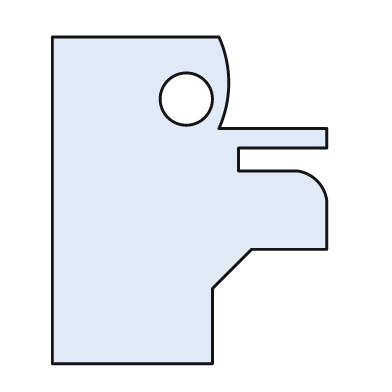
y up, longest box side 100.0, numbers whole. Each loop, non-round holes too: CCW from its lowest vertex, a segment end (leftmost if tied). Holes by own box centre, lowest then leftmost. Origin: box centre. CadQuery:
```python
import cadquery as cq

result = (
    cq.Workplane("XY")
    .moveTo(-42.0, -50.0)
    .lineTo(7.0, -50.0)
    .lineTo(7.0, -27.0)
    .lineTo(19.0, -15.0)
    .lineTo(42.0, -15.0)
    .lineTo(42.0, 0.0)
    .threePointArc((39.0, 6.0), (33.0, 9.0))
    .lineTo(15.0, 9.0)
    .lineTo(15.0, 16.0)
    .lineTo(42.0, 16.0)
    .lineTo(42.0, 22.0)
    .lineTo(9.0, 22.0)
    .threePointArc((12.0, 36.0), (9.0, 50.0))
    .lineTo(-42.0, 50.0)
    .close()
    .moveTo(-1.0, 31.0)
    .circle(8.0)
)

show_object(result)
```